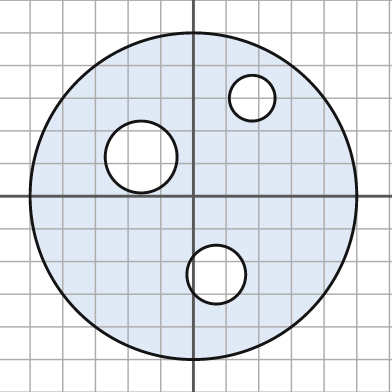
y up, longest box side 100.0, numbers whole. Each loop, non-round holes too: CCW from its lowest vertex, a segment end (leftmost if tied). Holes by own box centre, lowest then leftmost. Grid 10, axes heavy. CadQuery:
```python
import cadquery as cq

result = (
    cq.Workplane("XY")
    .moveTo(0.0, 0.0)
    .circle(50.0)
    .moveTo(7.0, -24.0)
    .circle(9.0)
    .moveTo(-16.0, 12.0)
    .circle(11.0)
    .moveTo(18.0, 30.0)
    .circle(7.0)
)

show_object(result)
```